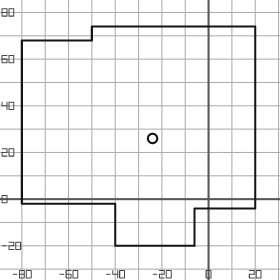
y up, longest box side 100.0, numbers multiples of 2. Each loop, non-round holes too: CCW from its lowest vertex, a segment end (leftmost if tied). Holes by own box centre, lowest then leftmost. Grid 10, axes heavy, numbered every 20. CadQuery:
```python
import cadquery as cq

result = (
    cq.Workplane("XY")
    .moveTo(-40.0, -20.0)
    .lineTo(-6.0, -20.0)
    .lineTo(-6.0, -4.0)
    .lineTo(20.0, -4.0)
    .lineTo(20.0, 74.0)
    .lineTo(-50.0, 74.0)
    .lineTo(-50.0, 68.0)
    .lineTo(-80.0, 68.0)
    .lineTo(-80.0, -2.0)
    .lineTo(-40.0, -2.0)
    .close()
    .moveTo(-24.0, 26.0)
    .circle(2.0)
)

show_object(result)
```